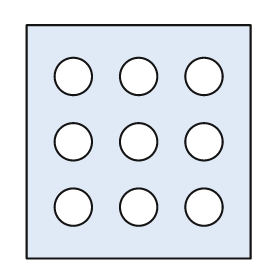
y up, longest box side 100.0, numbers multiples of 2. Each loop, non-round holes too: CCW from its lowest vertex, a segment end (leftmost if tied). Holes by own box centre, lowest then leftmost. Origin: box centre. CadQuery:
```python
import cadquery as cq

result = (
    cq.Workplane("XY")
    .moveTo(-48.0, -50.0)
    .lineTo(48.0, -50.0)
    .lineTo(48.0, 50.0)
    .lineTo(-48.0, 50.0)
    .close()
    .moveTo(-28.0, -28.0)
    .circle(8.0)
    .moveTo(0.0, -28.0)
    .circle(8.0)
    .moveTo(28.0, -28.0)
    .circle(8.0)
    .moveTo(-28.0, 0.0)
    .circle(8.0)
    .moveTo(0.0, 0.0)
    .circle(8.0)
    .moveTo(28.0, 0.0)
    .circle(8.0)
    .moveTo(-28.0, 28.0)
    .circle(8.0)
    .moveTo(0.0, 28.0)
    .circle(8.0)
    .moveTo(28.0, 28.0)
    .circle(8.0)
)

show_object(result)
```